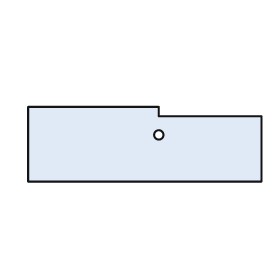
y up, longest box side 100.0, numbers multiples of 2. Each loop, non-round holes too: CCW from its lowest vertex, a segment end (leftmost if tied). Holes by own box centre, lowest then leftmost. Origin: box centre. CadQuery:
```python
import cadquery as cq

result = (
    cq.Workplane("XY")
    .moveTo(-50.0, -16.0)
    .lineTo(50.0, -16.0)
    .lineTo(50.0, 12.0)
    .lineTo(6.0, 12.0)
    .lineTo(6.0, 16.0)
    .lineTo(-50.0, 16.0)
    .close()
    .moveTo(6.0, 4.0)
    .circle(2.0)
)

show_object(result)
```